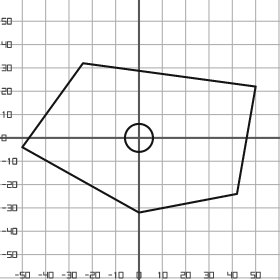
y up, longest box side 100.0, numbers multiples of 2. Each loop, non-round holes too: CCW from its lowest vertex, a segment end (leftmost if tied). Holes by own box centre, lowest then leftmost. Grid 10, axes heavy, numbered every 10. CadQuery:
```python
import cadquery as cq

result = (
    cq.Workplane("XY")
    .moveTo(0.0, -32.0)
    .lineTo(42.0, -24.0)
    .lineTo(50.0, 22.0)
    .lineTo(-24.0, 32.0)
    .lineTo(-50.0, -4.0)
    .close()
    .moveTo(0.0, 0.0)
    .circle(6.0)
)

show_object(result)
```